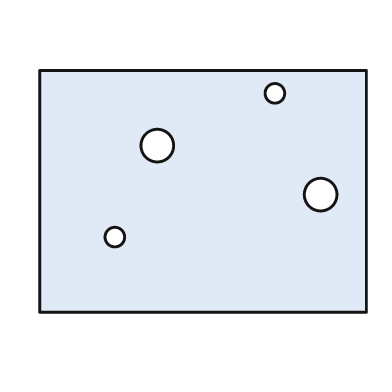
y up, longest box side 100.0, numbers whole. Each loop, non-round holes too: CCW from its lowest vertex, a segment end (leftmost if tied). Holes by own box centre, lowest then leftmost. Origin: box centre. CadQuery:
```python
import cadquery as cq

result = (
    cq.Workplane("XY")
    .moveTo(-50.0, -37.0)
    .lineTo(50.0, -37.0)
    .lineTo(50.0, 37.0)
    .lineTo(-50.0, 37.0)
    .close()
    .moveTo(-27.0, -14.0)
    .circle(3.0)
    .moveTo(36.0, -1.0)
    .circle(5.0)
    .moveTo(-14.0, 14.0)
    .circle(5.0)
    .moveTo(22.0, 30.0)
    .circle(3.0)
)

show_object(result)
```